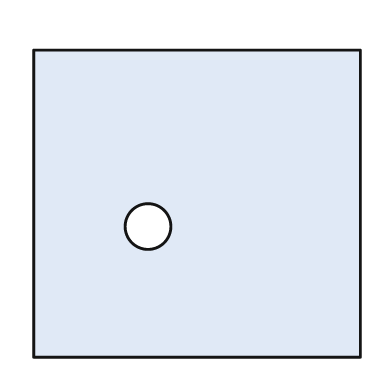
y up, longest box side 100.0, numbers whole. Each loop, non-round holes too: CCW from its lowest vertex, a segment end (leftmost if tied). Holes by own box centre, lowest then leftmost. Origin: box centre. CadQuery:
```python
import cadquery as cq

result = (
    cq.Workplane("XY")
    .moveTo(-50.0, -47.0)
    .lineTo(50.0, -47.0)
    .lineTo(50.0, 47.0)
    .lineTo(-50.0, 47.0)
    .close()
    .moveTo(-15.0, -7.0)
    .circle(7.0)
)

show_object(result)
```